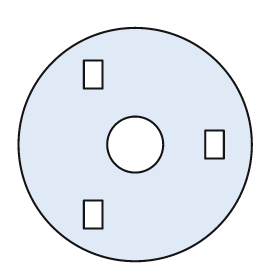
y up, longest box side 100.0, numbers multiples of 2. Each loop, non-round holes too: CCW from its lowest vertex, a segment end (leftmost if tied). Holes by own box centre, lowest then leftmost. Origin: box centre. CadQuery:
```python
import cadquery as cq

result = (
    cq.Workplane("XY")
    .moveTo(0.0, 0.0)
    .circle(50.0)
    .moveTo(-22.0, -36.0)
    .lineTo(-14.0, -36.0)
    .lineTo(-14.0, -24.0)
    .lineTo(-22.0, -24.0)
    .close()
    .moveTo(0.0, 0.0)
    .circle(12.0)
    .moveTo(30.0, -6.0)
    .lineTo(38.0, -6.0)
    .lineTo(38.0, 6.0)
    .lineTo(30.0, 6.0)
    .close()
    .moveTo(-22.0, 24.0)
    .lineTo(-14.0, 24.0)
    .lineTo(-14.0, 36.0)
    .lineTo(-22.0, 36.0)
    .close()
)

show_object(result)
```